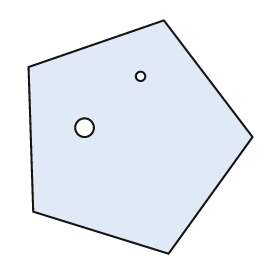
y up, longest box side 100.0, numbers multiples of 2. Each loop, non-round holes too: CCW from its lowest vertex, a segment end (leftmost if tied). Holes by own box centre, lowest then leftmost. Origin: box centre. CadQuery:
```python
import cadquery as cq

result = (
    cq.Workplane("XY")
    .moveTo(12.0, -50.0)
    .lineTo(48.0, 0.0)
    .lineTo(10.0, 50.0)
    .lineTo(-48.0, 30.0)
    .lineTo(-46.0, -32.0)
    .close()
    .moveTo(-24.0, 4.0)
    .circle(4.0)
    .moveTo(0.0, 26.0)
    .circle(2.0)
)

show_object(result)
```